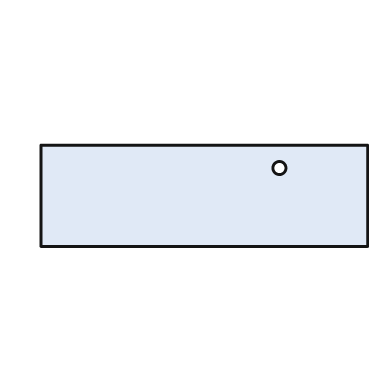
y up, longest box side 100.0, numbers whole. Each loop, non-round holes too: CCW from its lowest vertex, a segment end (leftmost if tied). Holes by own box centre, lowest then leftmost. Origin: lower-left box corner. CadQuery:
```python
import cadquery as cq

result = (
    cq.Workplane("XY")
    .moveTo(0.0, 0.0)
    .lineTo(100.0, 0.0)
    .lineTo(100.0, 31.0)
    .lineTo(0.0, 31.0)
    .close()
    .moveTo(73.0, 24.0)
    .circle(2.0)
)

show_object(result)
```